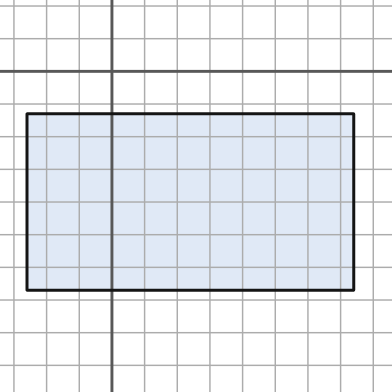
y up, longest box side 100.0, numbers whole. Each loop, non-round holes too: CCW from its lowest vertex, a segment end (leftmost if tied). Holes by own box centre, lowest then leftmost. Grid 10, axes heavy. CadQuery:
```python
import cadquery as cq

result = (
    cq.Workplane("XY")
    .moveTo(-26.0, -67.0)
    .lineTo(74.0, -67.0)
    .lineTo(74.0, -13.0)
    .lineTo(-26.0, -13.0)
    .close()
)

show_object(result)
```